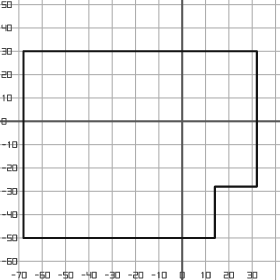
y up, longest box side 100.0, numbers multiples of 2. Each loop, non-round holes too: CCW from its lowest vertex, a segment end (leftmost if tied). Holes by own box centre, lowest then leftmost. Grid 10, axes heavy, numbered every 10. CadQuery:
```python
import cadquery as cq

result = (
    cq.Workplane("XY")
    .moveTo(-68.0, -50.0)
    .lineTo(14.0, -50.0)
    .lineTo(14.0, -28.0)
    .lineTo(32.0, -28.0)
    .lineTo(32.0, 30.0)
    .lineTo(-68.0, 30.0)
    .close()
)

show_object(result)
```